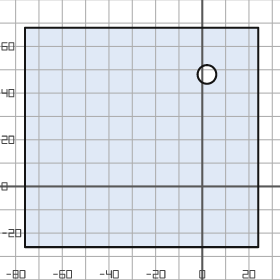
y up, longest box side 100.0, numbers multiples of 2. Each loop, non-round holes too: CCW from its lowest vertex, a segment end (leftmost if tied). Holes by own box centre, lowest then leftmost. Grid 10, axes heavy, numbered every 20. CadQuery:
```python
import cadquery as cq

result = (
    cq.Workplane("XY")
    .moveTo(-76.0, -26.0)
    .lineTo(24.0, -26.0)
    .lineTo(24.0, 68.0)
    .lineTo(-76.0, 68.0)
    .close()
    .moveTo(2.0, 48.0)
    .circle(4.0)
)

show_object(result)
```